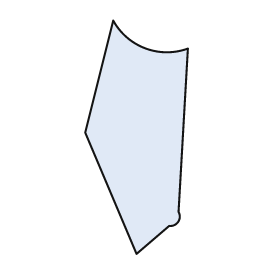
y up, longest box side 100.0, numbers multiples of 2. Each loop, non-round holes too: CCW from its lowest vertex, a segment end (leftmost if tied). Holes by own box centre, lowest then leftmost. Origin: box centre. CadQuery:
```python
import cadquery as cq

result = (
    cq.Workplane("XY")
    .moveTo(0.0, -50.0)
    .lineTo(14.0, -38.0)
    .threePointArc((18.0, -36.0), (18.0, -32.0))
    .lineTo(22.0, 38.0)
    .threePointArc((4.0, 38.0), (-10.0, 50.0))
    .lineTo(-22.0, 2.0)
    .close()
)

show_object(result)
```